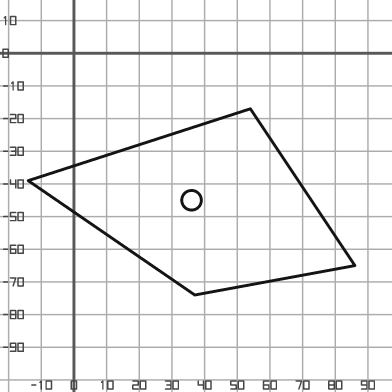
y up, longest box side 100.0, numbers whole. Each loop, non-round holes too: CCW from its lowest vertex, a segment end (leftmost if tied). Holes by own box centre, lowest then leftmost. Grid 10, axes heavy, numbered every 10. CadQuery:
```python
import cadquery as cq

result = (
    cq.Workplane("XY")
    .moveTo(37.0, -74.0)
    .lineTo(86.0, -65.0)
    .lineTo(54.0, -17.0)
    .lineTo(-14.0, -39.0)
    .close()
    .moveTo(36.0, -45.0)
    .circle(3.0)
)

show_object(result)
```